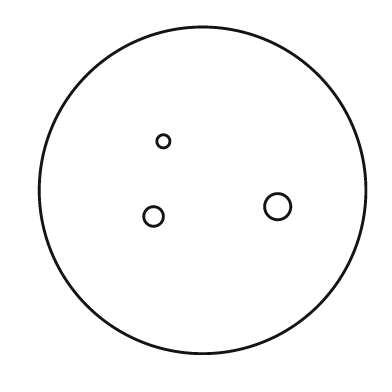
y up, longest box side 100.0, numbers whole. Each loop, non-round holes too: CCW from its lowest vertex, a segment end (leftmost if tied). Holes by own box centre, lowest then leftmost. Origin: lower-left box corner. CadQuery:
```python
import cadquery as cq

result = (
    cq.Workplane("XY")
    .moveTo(50.0, 50.0)
    .circle(50.0)
    .moveTo(35.0, 42.0)
    .circle(3.0)
    .moveTo(73.0, 45.0)
    .circle(4.0)
    .moveTo(38.0, 65.0)
    .circle(2.0)
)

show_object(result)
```